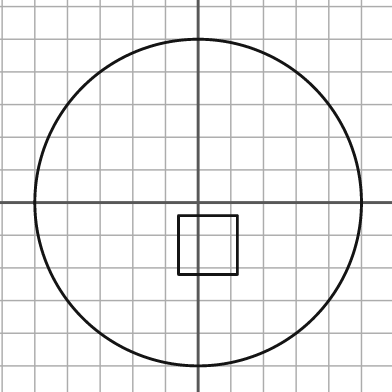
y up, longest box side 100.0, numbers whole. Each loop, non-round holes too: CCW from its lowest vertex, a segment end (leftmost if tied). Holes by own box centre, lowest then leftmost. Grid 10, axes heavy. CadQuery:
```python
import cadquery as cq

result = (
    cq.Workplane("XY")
    .moveTo(0.0, 0.0)
    .circle(50.0)
    .moveTo(-6.0, -22.0)
    .lineTo(12.0, -22.0)
    .lineTo(12.0, -4.0)
    .lineTo(-6.0, -4.0)
    .close()
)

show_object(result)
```